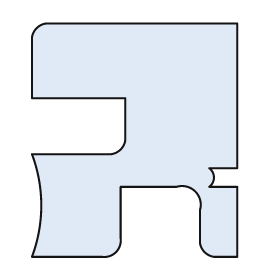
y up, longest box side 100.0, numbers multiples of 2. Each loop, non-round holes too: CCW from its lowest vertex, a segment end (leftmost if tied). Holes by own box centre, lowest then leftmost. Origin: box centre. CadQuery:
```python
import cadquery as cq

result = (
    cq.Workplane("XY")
    .moveTo(-44.0, -50.0)
    .lineTo(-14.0, -50.0)
    .threePointArc((-8.0, -48.0), (-6.0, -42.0))
    .lineTo(-6.0, -20.0)
    .lineTo(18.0, -20.0)
    .threePointArc((26.0, -22.0), (28.0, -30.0))
    .lineTo(28.0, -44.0)
    .threePointArc((30.0, -48.0), (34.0, -50.0))
    .lineTo(44.0, -50.0)
    .lineTo(44.0, -20.0)
    .lineTo(32.0, -20.0)
    .threePointArc((34.0, -16.0), (32.0, -12.0))
    .lineTo(44.0, -12.0)
    .lineTo(44.0, 50.0)
    .lineTo(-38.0, 50.0)
    .threePointArc((-42.0, 48.0), (-44.0, 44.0))
    .lineTo(-44.0, 18.0)
    .lineTo(-4.0, 18.0)
    .lineTo(-4.0, 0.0)
    .threePointArc((-6.0, -4.0), (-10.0, -6.0))
    .lineTo(-44.0, -6.0)
    .threePointArc((-40.0, -28.0), (-44.0, -50.0))
    .close()
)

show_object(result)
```